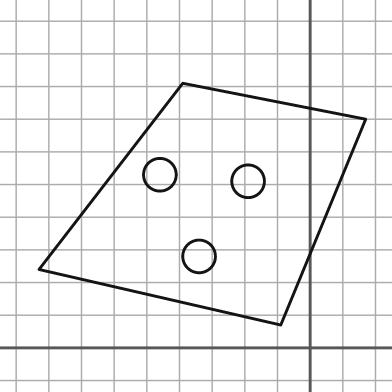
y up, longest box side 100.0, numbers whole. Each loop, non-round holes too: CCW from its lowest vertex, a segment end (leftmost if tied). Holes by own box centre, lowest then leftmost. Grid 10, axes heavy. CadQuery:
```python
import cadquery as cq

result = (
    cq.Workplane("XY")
    .moveTo(-9.0, 7.0)
    .lineTo(17.0, 70.0)
    .lineTo(-39.0, 81.0)
    .lineTo(-83.0, 24.0)
    .close()
    .moveTo(-34.0, 28.0)
    .circle(5.0)
    .moveTo(-19.0, 51.0)
    .circle(5.0)
    .moveTo(-46.0, 53.0)
    .circle(5.0)
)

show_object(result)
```